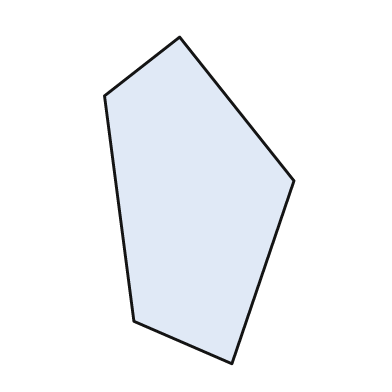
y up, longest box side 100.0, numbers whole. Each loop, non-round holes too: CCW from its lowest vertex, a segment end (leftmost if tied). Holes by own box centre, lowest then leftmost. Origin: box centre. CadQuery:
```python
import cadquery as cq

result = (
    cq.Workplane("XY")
    .moveTo(10.0, -50.0)
    .lineTo(29.0, 6.0)
    .lineTo(-6.0, 50.0)
    .lineTo(-29.0, 32.0)
    .lineTo(-20.0, -37.0)
    .close()
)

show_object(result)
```